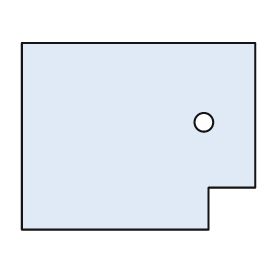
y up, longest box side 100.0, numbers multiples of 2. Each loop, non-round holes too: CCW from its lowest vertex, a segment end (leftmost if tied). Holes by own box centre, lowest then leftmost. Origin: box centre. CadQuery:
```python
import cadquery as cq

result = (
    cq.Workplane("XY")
    .moveTo(-50.0, -40.0)
    .lineTo(30.0, -40.0)
    .lineTo(30.0, -22.0)
    .lineTo(50.0, -22.0)
    .lineTo(50.0, 40.0)
    .lineTo(-50.0, 40.0)
    .close()
    .moveTo(28.0, 6.0)
    .circle(4.0)
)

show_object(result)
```